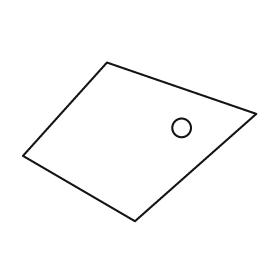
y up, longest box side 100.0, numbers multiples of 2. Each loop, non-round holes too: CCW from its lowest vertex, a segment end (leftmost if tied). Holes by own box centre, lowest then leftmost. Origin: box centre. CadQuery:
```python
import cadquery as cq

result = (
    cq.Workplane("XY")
    .moveTo(-2.0, -34.0)
    .lineTo(50.0, 12.0)
    .lineTo(-14.0, 34.0)
    .lineTo(-50.0, -6.0)
    .close()
    .moveTo(18.0, 6.0)
    .circle(4.0)
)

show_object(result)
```